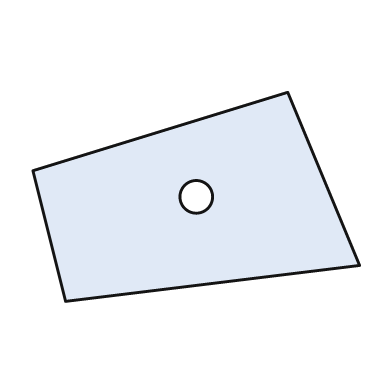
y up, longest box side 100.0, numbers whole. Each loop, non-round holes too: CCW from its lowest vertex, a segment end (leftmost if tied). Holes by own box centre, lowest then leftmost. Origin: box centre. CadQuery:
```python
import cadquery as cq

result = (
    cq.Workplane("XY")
    .moveTo(-40.0, -32.0)
    .lineTo(50.0, -21.0)
    .lineTo(28.0, 32.0)
    .lineTo(-50.0, 8.0)
    .close()
    .moveTo(0.0, 0.0)
    .circle(5.0)
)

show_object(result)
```